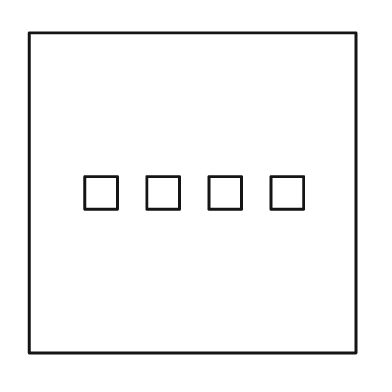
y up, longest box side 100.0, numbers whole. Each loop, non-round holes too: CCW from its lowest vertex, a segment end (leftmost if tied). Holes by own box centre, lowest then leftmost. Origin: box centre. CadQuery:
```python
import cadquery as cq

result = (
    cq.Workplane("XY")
    .moveTo(-50.0, -49.0)
    .lineTo(50.0, -49.0)
    .lineTo(50.0, 49.0)
    .lineTo(-50.0, 49.0)
    .close()
    .moveTo(-33.0, -5.0)
    .lineTo(-23.0, -5.0)
    .lineTo(-23.0, 5.0)
    .lineTo(-33.0, 5.0)
    .close()
    .moveTo(-14.0, -5.0)
    .lineTo(-4.0, -5.0)
    .lineTo(-4.0, 5.0)
    .lineTo(-14.0, 5.0)
    .close()
    .moveTo(5.0, -5.0)
    .lineTo(15.0, -5.0)
    .lineTo(15.0, 5.0)
    .lineTo(5.0, 5.0)
    .close()
    .moveTo(24.0, -5.0)
    .lineTo(34.0, -5.0)
    .lineTo(34.0, 5.0)
    .lineTo(24.0, 5.0)
    .close()
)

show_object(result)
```